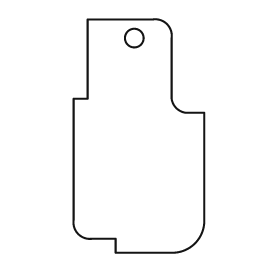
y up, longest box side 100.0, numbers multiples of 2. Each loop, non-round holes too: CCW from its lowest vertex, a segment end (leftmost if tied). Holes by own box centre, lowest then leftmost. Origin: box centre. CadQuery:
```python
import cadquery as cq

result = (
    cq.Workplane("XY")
    .moveTo(-10.0, -50.0)
    .lineTo(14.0, -50.0)
    .threePointArc((24.0, -46.0), (28.0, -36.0))
    .lineTo(28.0, 10.0)
    .lineTo(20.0, 10.0)
    .threePointArc((16.0, 12.0), (14.0, 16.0))
    .lineTo(14.0, 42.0)
    .threePointArc((12.0, 48.0), (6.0, 50.0))
    .lineTo(-22.0, 50.0)
    .lineTo(-22.0, 16.0)
    .lineTo(-28.0, 16.0)
    .lineTo(-28.0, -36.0)
    .threePointArc((-26.0, -42.0), (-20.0, -44.0))
    .lineTo(-10.0, -44.0)
    .close()
    .moveTo(-2.0, 42.0)
    .circle(4.0)
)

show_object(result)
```